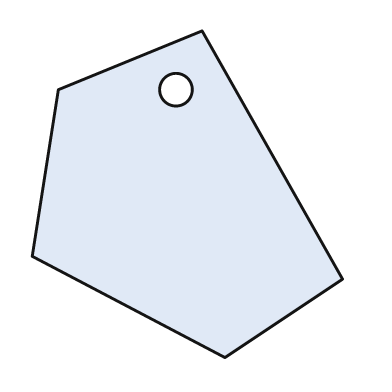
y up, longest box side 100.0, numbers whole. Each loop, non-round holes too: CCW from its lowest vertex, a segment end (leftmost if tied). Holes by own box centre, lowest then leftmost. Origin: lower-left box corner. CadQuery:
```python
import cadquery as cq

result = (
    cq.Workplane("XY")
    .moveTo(59.0, 0.0)
    .lineTo(95.0, 24.0)
    .lineTo(52.0, 100.0)
    .lineTo(8.0, 82.0)
    .lineTo(0.0, 31.0)
    .close()
    .moveTo(44.0, 82.0)
    .circle(5.0)
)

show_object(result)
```